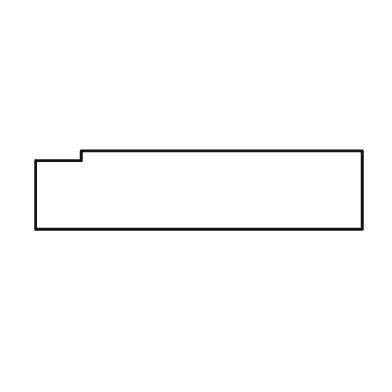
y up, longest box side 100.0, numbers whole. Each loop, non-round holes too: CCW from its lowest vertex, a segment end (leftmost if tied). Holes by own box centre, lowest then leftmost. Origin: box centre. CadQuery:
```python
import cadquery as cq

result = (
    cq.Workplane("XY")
    .moveTo(-50.0, -12.0)
    .lineTo(50.0, -12.0)
    .lineTo(50.0, 12.0)
    .lineTo(-36.0, 12.0)
    .lineTo(-36.0, 9.0)
    .lineTo(-50.0, 9.0)
    .close()
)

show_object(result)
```